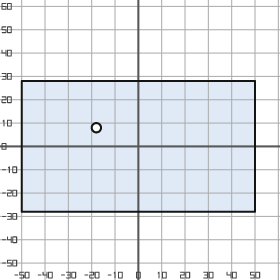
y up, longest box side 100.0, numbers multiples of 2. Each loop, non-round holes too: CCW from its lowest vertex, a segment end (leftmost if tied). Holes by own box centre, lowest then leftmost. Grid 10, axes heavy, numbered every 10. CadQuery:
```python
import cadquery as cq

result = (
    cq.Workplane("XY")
    .moveTo(-50.0, -28.0)
    .lineTo(50.0, -28.0)
    .lineTo(50.0, 28.0)
    .lineTo(-50.0, 28.0)
    .close()
    .moveTo(-18.0, 8.0)
    .circle(2.0)
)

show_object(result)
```